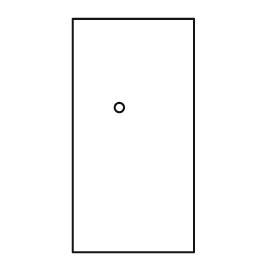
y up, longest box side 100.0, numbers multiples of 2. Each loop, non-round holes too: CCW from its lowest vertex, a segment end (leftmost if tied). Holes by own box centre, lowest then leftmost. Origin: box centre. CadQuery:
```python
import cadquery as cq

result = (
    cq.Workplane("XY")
    .moveTo(-26.0, -50.0)
    .lineTo(26.0, -50.0)
    .lineTo(26.0, 50.0)
    .lineTo(-26.0, 50.0)
    .close()
    .moveTo(-6.0, 12.0)
    .circle(2.0)
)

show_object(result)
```